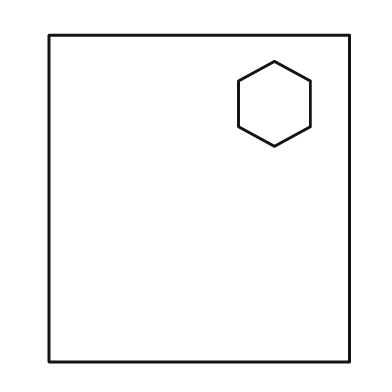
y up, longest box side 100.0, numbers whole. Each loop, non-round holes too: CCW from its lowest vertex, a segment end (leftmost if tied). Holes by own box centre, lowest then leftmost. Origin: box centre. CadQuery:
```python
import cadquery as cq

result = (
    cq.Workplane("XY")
    .moveTo(-46.0, -50.0)
    .lineTo(46.0, -50.0)
    .lineTo(46.0, 50.0)
    .lineTo(-46.0, 50.0)
    .close()
    .moveTo(23.0, 16.0)
    .lineTo(34.0, 22.0)
    .lineTo(34.0, 36.0)
    .lineTo(23.0, 42.0)
    .lineTo(12.0, 36.0)
    .lineTo(12.0, 22.0)
    .close()
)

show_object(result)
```